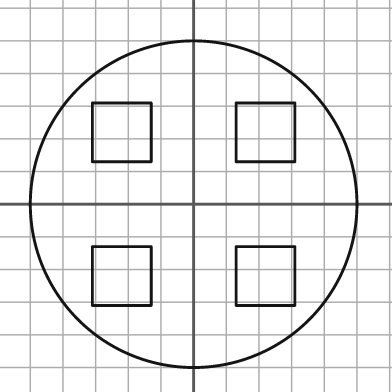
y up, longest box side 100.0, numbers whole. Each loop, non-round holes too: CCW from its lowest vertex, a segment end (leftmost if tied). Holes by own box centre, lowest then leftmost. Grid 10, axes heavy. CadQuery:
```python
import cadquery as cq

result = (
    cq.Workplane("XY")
    .moveTo(0.0, 0.0)
    .circle(50.0)
    .moveTo(-31.0, -31.0)
    .lineTo(-13.0, -31.0)
    .lineTo(-13.0, -13.0)
    .lineTo(-31.0, -13.0)
    .close()
    .moveTo(13.0, -31.0)
    .lineTo(31.0, -31.0)
    .lineTo(31.0, -13.0)
    .lineTo(13.0, -13.0)
    .close()
    .moveTo(-31.0, 13.0)
    .lineTo(-13.0, 13.0)
    .lineTo(-13.0, 31.0)
    .lineTo(-31.0, 31.0)
    .close()
    .moveTo(13.0, 13.0)
    .lineTo(31.0, 13.0)
    .lineTo(31.0, 31.0)
    .lineTo(13.0, 31.0)
    .close()
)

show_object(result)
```